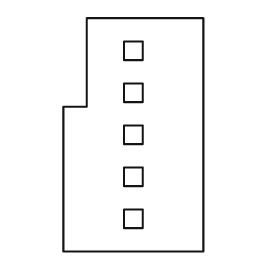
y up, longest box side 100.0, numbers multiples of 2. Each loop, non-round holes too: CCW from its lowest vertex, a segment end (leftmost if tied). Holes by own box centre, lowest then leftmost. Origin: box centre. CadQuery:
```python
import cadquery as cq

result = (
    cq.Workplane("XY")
    .moveTo(-30.0, -50.0)
    .lineTo(30.0, -50.0)
    .lineTo(30.0, 50.0)
    .lineTo(-20.0, 50.0)
    .lineTo(-20.0, 12.0)
    .lineTo(-30.0, 12.0)
    .close()
    .moveTo(-4.0, -40.0)
    .lineTo(4.0, -40.0)
    .lineTo(4.0, -32.0)
    .lineTo(-4.0, -32.0)
    .close()
    .moveTo(-4.0, -22.0)
    .lineTo(4.0, -22.0)
    .lineTo(4.0, -14.0)
    .lineTo(-4.0, -14.0)
    .close()
    .moveTo(-4.0, -4.0)
    .lineTo(4.0, -4.0)
    .lineTo(4.0, 4.0)
    .lineTo(-4.0, 4.0)
    .close()
    .moveTo(-4.0, 14.0)
    .lineTo(4.0, 14.0)
    .lineTo(4.0, 22.0)
    .lineTo(-4.0, 22.0)
    .close()
    .moveTo(-4.0, 32.0)
    .lineTo(4.0, 32.0)
    .lineTo(4.0, 40.0)
    .lineTo(-4.0, 40.0)
    .close()
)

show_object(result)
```